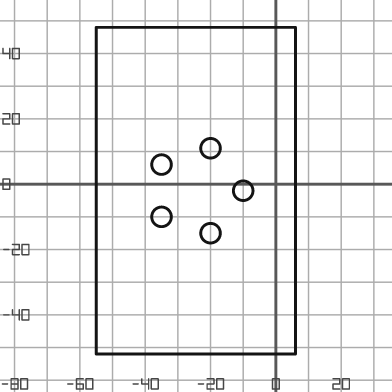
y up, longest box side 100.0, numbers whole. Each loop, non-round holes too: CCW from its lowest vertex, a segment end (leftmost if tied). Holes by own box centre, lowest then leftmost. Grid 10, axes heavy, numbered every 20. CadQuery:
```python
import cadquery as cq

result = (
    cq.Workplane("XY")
    .moveTo(-55.0, -52.0)
    .lineTo(6.0, -52.0)
    .lineTo(6.0, 48.0)
    .lineTo(-55.0, 48.0)
    .close()
    .moveTo(-20.0, -15.0)
    .circle(3.0)
    .moveTo(-35.0, -10.0)
    .circle(3.0)
    .moveTo(-10.0, -2.0)
    .circle(3.0)
    .moveTo(-35.0, 6.0)
    .circle(3.0)
    .moveTo(-20.0, 11.0)
    .circle(3.0)
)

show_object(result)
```